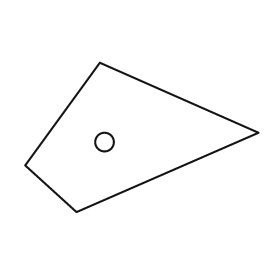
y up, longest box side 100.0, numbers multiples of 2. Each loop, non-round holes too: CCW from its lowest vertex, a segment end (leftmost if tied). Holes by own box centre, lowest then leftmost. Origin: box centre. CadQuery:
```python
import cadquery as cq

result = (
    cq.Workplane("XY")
    .moveTo(-28.0, -32.0)
    .lineTo(50.0, 2.0)
    .lineTo(-18.0, 32.0)
    .lineTo(-50.0, -12.0)
    .close()
    .moveTo(-16.0, -2.0)
    .circle(4.0)
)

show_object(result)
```